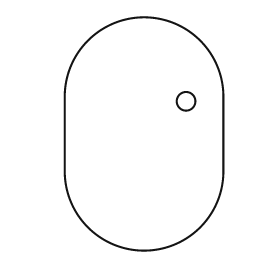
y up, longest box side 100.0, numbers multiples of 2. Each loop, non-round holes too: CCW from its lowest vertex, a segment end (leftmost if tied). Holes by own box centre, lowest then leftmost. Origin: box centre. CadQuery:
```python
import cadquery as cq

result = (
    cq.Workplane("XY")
    .moveTo(-34.0, -16.0)
    .threePointArc((0.0, -50.0), (34.0, -16.0))
    .lineTo(34.0, 16.0)
    .threePointArc((0.0, 50.0), (-34.0, 16.0))
    .close()
    .moveTo(18.0, 14.0)
    .circle(4.0)
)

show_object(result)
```